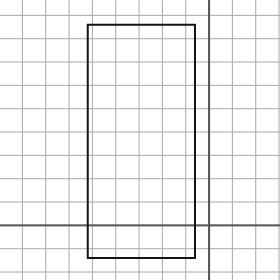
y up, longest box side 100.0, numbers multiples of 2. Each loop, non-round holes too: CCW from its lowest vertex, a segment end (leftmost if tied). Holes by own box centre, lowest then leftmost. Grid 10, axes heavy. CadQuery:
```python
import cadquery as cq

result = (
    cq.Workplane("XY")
    .moveTo(-52.0, -14.0)
    .lineTo(-6.0, -14.0)
    .lineTo(-6.0, 86.0)
    .lineTo(-52.0, 86.0)
    .close()
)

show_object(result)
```